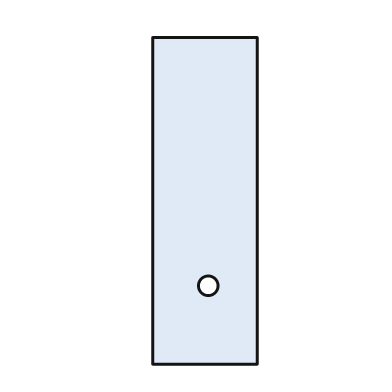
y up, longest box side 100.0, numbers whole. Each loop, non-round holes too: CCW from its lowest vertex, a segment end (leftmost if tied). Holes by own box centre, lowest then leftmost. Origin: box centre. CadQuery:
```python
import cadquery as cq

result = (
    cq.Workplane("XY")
    .moveTo(-16.0, -50.0)
    .lineTo(16.0, -50.0)
    .lineTo(16.0, 50.0)
    .lineTo(-16.0, 50.0)
    .close()
    .moveTo(1.0, -26.0)
    .circle(3.0)
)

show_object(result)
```